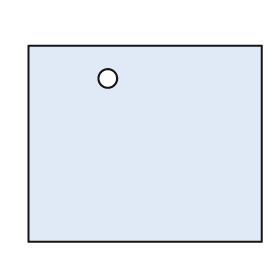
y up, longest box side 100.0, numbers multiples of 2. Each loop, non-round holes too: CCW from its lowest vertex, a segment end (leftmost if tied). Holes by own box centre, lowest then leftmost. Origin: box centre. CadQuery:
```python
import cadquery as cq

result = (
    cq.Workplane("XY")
    .moveTo(-50.0, -42.0)
    .lineTo(50.0, -42.0)
    .lineTo(50.0, 42.0)
    .lineTo(-50.0, 42.0)
    .close()
    .moveTo(-16.0, 28.0)
    .circle(4.0)
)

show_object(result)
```